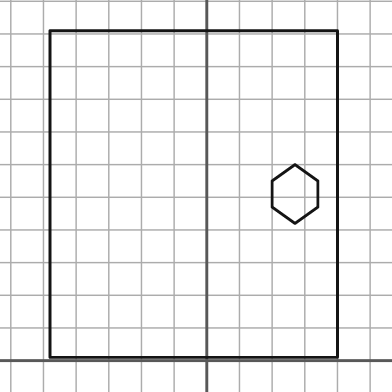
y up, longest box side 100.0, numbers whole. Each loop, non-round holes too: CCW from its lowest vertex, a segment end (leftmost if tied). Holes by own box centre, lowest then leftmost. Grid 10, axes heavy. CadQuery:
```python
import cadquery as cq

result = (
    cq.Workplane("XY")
    .moveTo(-48.0, 1.0)
    .lineTo(40.0, 1.0)
    .lineTo(40.0, 101.0)
    .lineTo(-48.0, 101.0)
    .close()
    .moveTo(27.0, 42.0)
    .lineTo(34.0, 47.0)
    .lineTo(34.0, 55.0)
    .lineTo(27.0, 60.0)
    .lineTo(20.0, 55.0)
    .lineTo(20.0, 47.0)
    .close()
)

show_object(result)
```